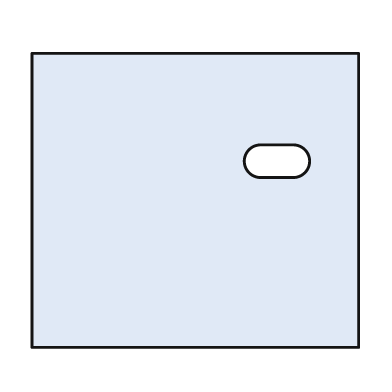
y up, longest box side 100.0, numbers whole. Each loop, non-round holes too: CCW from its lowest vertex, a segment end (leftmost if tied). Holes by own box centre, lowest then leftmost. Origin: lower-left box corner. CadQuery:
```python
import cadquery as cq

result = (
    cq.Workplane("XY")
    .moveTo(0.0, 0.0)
    .lineTo(100.0, 0.0)
    .lineTo(100.0, 90.0)
    .lineTo(0.0, 90.0)
    .close()
    .moveTo(70.0, 52.0)
    .lineTo(80.0, 52.0)
    .threePointArc((85.0, 57.0), (80.0, 62.0))
    .lineTo(70.0, 62.0)
    .threePointArc((65.0, 57.0), (70.0, 52.0))
    .close()
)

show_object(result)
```